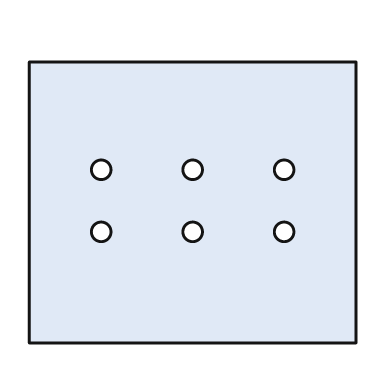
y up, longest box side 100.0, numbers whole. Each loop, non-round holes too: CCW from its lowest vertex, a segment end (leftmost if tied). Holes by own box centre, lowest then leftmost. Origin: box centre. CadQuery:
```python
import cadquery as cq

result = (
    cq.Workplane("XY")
    .moveTo(-50.0, -43.0)
    .lineTo(50.0, -43.0)
    .lineTo(50.0, 43.0)
    .lineTo(-50.0, 43.0)
    .close()
    .moveTo(-28.0, -9.0)
    .circle(3.0)
    .moveTo(0.0, -9.0)
    .circle(3.0)
    .moveTo(28.0, -9.0)
    .circle(3.0)
    .moveTo(-28.0, 10.0)
    .circle(3.0)
    .moveTo(0.0, 10.0)
    .circle(3.0)
    .moveTo(28.0, 10.0)
    .circle(3.0)
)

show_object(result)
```